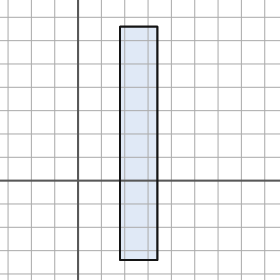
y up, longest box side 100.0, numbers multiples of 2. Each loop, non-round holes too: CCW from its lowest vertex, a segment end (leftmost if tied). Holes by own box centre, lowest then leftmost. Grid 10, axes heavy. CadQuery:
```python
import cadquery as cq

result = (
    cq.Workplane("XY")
    .moveTo(18.0, -34.0)
    .lineTo(34.0, -34.0)
    .lineTo(34.0, 66.0)
    .lineTo(18.0, 66.0)
    .close()
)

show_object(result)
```